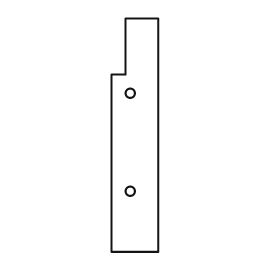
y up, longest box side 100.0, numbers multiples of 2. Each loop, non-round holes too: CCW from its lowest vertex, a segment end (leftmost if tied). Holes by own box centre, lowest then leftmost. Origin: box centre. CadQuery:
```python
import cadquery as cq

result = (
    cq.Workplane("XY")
    .moveTo(-10.0, -50.0)
    .lineTo(10.0, -50.0)
    .lineTo(10.0, 50.0)
    .lineTo(-4.0, 50.0)
    .lineTo(-4.0, 26.0)
    .lineTo(-10.0, 26.0)
    .close()
    .moveTo(-2.0, -24.0)
    .circle(2.0)
    .moveTo(-2.0, 18.0)
    .circle(2.0)
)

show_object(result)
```